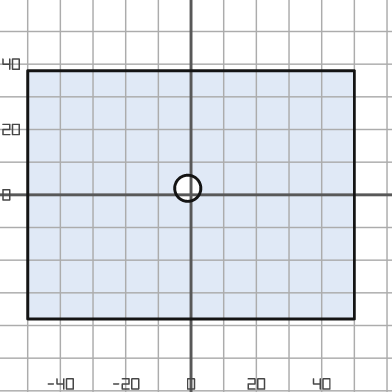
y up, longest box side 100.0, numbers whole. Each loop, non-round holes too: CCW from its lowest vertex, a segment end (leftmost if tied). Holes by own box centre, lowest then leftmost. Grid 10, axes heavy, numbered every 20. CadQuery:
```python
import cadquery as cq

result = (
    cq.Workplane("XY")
    .moveTo(-50.0, -38.0)
    .lineTo(50.0, -38.0)
    .lineTo(50.0, 38.0)
    .lineTo(-50.0, 38.0)
    .close()
    .moveTo(-1.0, 2.0)
    .circle(4.0)
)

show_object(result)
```